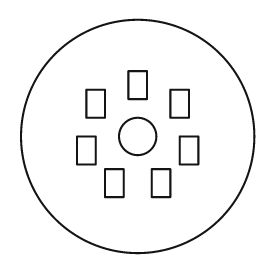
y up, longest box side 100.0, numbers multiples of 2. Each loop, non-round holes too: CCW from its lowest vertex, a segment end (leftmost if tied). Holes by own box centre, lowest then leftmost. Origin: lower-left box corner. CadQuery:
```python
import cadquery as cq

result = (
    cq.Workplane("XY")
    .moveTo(50.0, 50.0)
    .circle(50.0)
    .moveTo(36.0, 24.0)
    .lineTo(44.0, 24.0)
    .lineTo(44.0, 36.0)
    .lineTo(36.0, 36.0)
    .close()
    .moveTo(56.0, 24.0)
    .lineTo(64.0, 24.0)
    .lineTo(64.0, 36.0)
    .lineTo(56.0, 36.0)
    .close()
    .moveTo(24.0, 38.0)
    .lineTo(32.0, 38.0)
    .lineTo(32.0, 50.0)
    .lineTo(24.0, 50.0)
    .close()
    .moveTo(68.0, 38.0)
    .lineTo(76.0, 38.0)
    .lineTo(76.0, 50.0)
    .lineTo(68.0, 50.0)
    .close()
    .moveTo(50.0, 50.0)
    .circle(8.0)
    .moveTo(28.0, 58.0)
    .lineTo(36.0, 58.0)
    .lineTo(36.0, 70.0)
    .lineTo(28.0, 70.0)
    .close()
    .moveTo(64.0, 58.0)
    .lineTo(72.0, 58.0)
    .lineTo(72.0, 70.0)
    .lineTo(64.0, 70.0)
    .close()
    .moveTo(46.0, 66.0)
    .lineTo(54.0, 66.0)
    .lineTo(54.0, 78.0)
    .lineTo(46.0, 78.0)
    .close()
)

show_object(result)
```